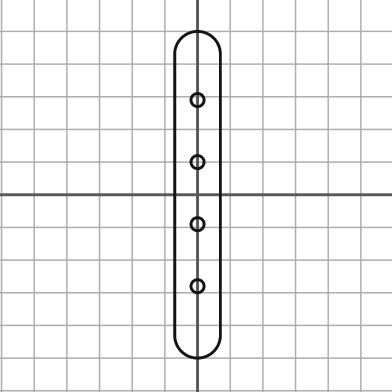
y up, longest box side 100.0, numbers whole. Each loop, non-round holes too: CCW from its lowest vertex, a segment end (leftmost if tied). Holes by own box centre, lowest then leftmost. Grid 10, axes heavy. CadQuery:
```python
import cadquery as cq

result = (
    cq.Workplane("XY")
    .moveTo(-7.0, -43.0)
    .threePointArc((0.0, -50.0), (7.0, -43.0))
    .lineTo(7.0, 43.0)
    .threePointArc((0.0, 50.0), (-7.0, 43.0))
    .close()
    .moveTo(0.0, -28.0)
    .circle(2.0)
    .moveTo(0.0, -9.0)
    .circle(2.0)
    .moveTo(0.0, 10.0)
    .circle(2.0)
    .moveTo(0.0, 29.0)
    .circle(2.0)
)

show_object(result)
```